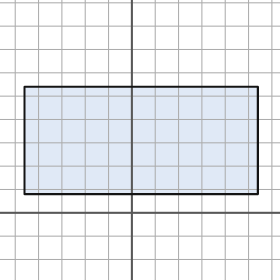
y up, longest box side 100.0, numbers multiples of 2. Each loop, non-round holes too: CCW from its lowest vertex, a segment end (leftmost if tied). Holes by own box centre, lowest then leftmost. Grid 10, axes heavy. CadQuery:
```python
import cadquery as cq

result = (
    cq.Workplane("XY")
    .moveTo(-46.0, 8.0)
    .lineTo(54.0, 8.0)
    .lineTo(54.0, 54.0)
    .lineTo(-46.0, 54.0)
    .close()
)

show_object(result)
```